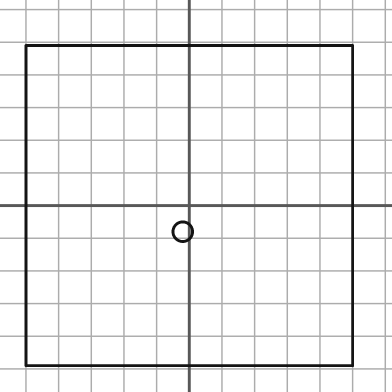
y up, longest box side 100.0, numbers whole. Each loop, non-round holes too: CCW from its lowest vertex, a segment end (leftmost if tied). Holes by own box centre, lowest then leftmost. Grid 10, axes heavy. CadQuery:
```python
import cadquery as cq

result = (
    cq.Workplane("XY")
    .moveTo(-50.0, -49.0)
    .lineTo(50.0, -49.0)
    .lineTo(50.0, 49.0)
    .lineTo(-50.0, 49.0)
    .close()
    .moveTo(-2.0, -8.0)
    .circle(3.0)
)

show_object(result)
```